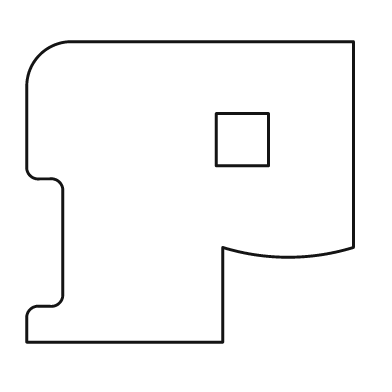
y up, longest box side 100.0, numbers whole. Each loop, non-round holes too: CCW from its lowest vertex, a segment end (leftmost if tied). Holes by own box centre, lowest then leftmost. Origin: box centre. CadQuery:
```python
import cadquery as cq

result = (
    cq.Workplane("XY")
    .moveTo(-50.0, -46.0)
    .lineTo(10.0, -46.0)
    .lineTo(10.0, -17.0)
    .threePointArc((30.0, -20.0), (50.0, -17.0))
    .lineTo(50.0, 46.0)
    .lineTo(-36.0, 46.0)
    .threePointArc((-46.0, 42.0), (-50.0, 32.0))
    .lineTo(-50.0, 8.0)
    .threePointArc((-49.0, 5.0), (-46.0, 4.0))
    .lineTo(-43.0, 4.0)
    .threePointArc((-40.0, 3.0), (-39.0, 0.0))
    .lineTo(-39.0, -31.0)
    .threePointArc((-40.0, -34.0), (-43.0, -35.0))
    .lineTo(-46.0, -35.0)
    .threePointArc((-49.0, -36.0), (-50.0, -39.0))
    .close()
    .moveTo(8.0, 8.0)
    .lineTo(24.0, 8.0)
    .lineTo(24.0, 24.0)
    .lineTo(8.0, 24.0)
    .close()
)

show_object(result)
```